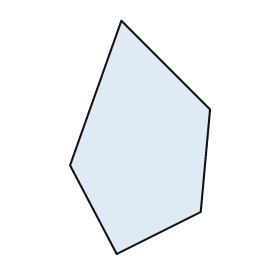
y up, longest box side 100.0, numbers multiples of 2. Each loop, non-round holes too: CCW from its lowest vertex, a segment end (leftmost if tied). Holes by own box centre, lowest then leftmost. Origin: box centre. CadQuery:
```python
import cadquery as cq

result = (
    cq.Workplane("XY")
    .moveTo(-10.0, -50.0)
    .lineTo(26.0, -32.0)
    .lineTo(30.0, 12.0)
    .lineTo(-8.0, 50.0)
    .lineTo(-30.0, -12.0)
    .close()
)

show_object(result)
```